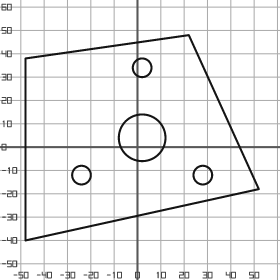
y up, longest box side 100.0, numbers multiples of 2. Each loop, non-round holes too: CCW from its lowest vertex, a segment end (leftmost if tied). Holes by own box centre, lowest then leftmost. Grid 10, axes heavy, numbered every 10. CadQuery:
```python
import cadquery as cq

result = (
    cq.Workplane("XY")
    .moveTo(-48.0, -40.0)
    .lineTo(52.0, -18.0)
    .lineTo(22.0, 48.0)
    .lineTo(-48.0, 38.0)
    .close()
    .moveTo(-24.0, -12.0)
    .circle(4.0)
    .moveTo(28.0, -12.0)
    .circle(4.0)
    .moveTo(2.0, 4.0)
    .circle(10.0)
    .moveTo(2.0, 34.0)
    .circle(4.0)
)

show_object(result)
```